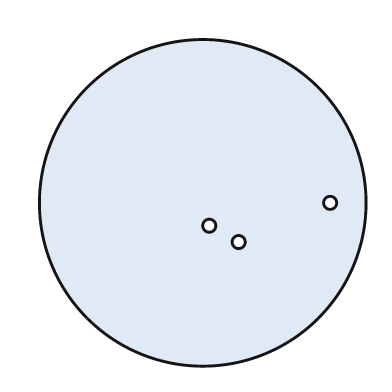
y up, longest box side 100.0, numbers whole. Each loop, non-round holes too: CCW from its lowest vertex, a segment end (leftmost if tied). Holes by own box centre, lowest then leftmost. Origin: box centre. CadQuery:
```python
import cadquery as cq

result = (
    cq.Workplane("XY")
    .moveTo(0.0, 0.0)
    .circle(50.0)
    .moveTo(11.0, -12.0)
    .circle(2.0)
    .moveTo(2.0, -7.0)
    .circle(2.0)
    .moveTo(39.0, 0.0)
    .circle(2.0)
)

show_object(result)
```